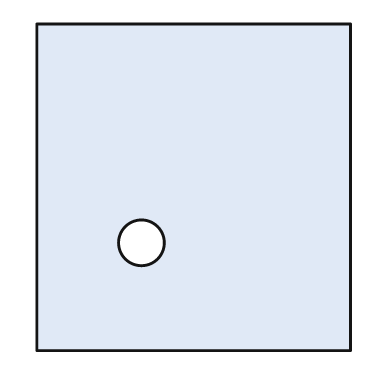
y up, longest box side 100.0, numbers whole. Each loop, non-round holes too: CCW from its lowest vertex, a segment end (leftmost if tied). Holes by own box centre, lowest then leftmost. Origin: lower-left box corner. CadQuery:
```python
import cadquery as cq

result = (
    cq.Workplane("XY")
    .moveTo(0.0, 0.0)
    .lineTo(96.0, 0.0)
    .lineTo(96.0, 100.0)
    .lineTo(0.0, 100.0)
    .close()
    .moveTo(32.0, 33.0)
    .circle(7.0)
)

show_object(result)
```